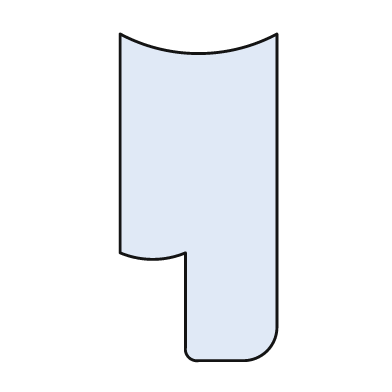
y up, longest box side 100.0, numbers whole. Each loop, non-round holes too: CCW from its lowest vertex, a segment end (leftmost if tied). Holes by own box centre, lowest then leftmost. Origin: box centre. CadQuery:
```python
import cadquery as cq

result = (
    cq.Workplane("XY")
    .moveTo(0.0, -50.0)
    .lineTo(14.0, -50.0)
    .threePointArc((21.0, -47.0), (24.0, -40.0))
    .lineTo(24.0, 50.0)
    .threePointArc((0.0, 44.0), (-24.0, 50.0))
    .lineTo(-24.0, -17.0)
    .threePointArc((-14.0, -19.0), (-4.0, -17.0))
    .lineTo(-4.0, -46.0)
    .threePointArc((-3.0, -49.0), (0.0, -50.0))
    .close()
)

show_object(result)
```